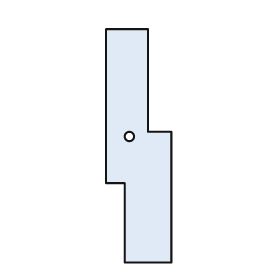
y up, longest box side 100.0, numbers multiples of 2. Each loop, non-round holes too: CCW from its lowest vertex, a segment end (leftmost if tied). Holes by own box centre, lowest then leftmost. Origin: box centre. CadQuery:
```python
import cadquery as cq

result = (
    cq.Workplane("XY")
    .moveTo(-6.0, -50.0)
    .lineTo(14.0, -50.0)
    .lineTo(14.0, 6.0)
    .lineTo(4.0, 6.0)
    .lineTo(4.0, 50.0)
    .lineTo(-14.0, 50.0)
    .lineTo(-14.0, -16.0)
    .lineTo(-6.0, -16.0)
    .close()
    .moveTo(-4.0, 4.0)
    .circle(2.0)
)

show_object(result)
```